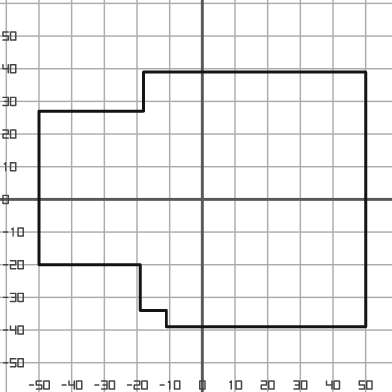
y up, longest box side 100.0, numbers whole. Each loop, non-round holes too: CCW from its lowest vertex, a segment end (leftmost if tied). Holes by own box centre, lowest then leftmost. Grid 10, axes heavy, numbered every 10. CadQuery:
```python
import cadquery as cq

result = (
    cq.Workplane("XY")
    .moveTo(-11.0, -39.0)
    .lineTo(50.0, -39.0)
    .lineTo(50.0, 39.0)
    .lineTo(-18.0, 39.0)
    .lineTo(-18.0, 27.0)
    .lineTo(-50.0, 27.0)
    .lineTo(-50.0, -20.0)
    .lineTo(-19.0, -20.0)
    .lineTo(-19.0, -34.0)
    .lineTo(-11.0, -34.0)
    .close()
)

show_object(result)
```